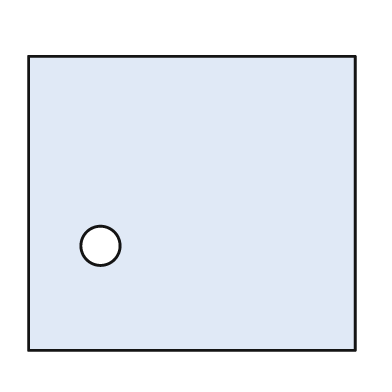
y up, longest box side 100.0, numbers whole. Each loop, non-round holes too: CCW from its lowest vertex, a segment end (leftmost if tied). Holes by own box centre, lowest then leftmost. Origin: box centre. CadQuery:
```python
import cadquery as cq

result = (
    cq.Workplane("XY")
    .moveTo(-50.0, -45.0)
    .lineTo(50.0, -45.0)
    .lineTo(50.0, 45.0)
    .lineTo(-50.0, 45.0)
    .close()
    .moveTo(-28.0, -13.0)
    .circle(6.0)
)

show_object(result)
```